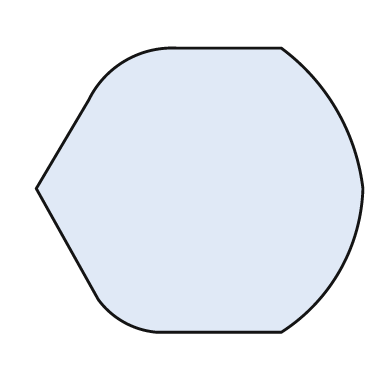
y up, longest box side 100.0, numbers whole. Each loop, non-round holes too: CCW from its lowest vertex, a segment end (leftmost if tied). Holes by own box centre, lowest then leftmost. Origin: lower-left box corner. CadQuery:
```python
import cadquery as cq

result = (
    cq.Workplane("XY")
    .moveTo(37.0, 0.0)
    .lineTo(75.0, 0.0)
    .threePointArc((93.0, 19.0), (100.0, 44.0))
    .threePointArc((92.0, 68.0), (75.0, 87.0))
    .lineTo(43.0, 87.0)
    .threePointArc((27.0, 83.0), (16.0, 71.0))
    .lineTo(0.0, 44.0)
    .lineTo(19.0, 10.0)
    .threePointArc((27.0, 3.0), (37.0, 0.0))
    .close()
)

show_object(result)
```